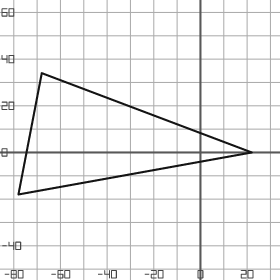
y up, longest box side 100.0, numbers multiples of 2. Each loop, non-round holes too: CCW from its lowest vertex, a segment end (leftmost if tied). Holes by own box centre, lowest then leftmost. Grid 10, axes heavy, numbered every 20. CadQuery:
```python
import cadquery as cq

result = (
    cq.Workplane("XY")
    .moveTo(-78.0, -18.0)
    .lineTo(22.0, 0.0)
    .lineTo(-68.0, 34.0)
    .close()
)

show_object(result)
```